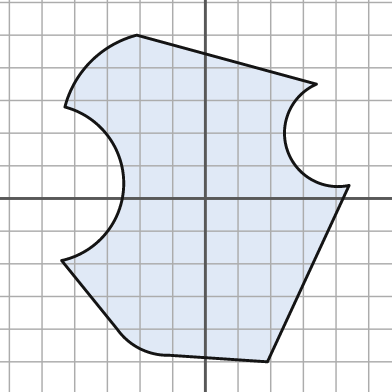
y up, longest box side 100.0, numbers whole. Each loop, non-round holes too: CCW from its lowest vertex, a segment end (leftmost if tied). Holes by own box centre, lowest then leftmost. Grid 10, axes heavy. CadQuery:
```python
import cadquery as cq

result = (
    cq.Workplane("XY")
    .moveTo(19.0, -50.0)
    .lineTo(44.0, 4.0)
    .threePointArc((25.0, 15.0), (34.0, 35.0))
    .lineTo(-21.0, 50.0)
    .threePointArc((-35.0, 42.0), (-43.0, 28.0))
    .threePointArc((-25.0, 4.0), (-44.0, -19.0))
    .lineTo(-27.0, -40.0)
    .threePointArc((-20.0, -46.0), (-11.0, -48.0))
    .close()
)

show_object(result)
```